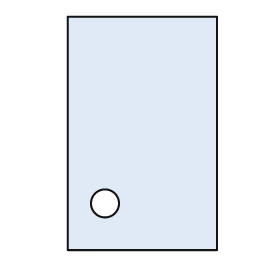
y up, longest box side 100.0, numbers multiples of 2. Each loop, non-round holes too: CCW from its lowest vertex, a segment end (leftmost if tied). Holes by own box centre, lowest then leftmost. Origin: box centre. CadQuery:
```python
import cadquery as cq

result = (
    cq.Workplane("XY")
    .moveTo(-32.0, -50.0)
    .lineTo(32.0, -50.0)
    .lineTo(32.0, 50.0)
    .lineTo(-32.0, 50.0)
    .close()
    .moveTo(-16.0, -30.0)
    .circle(6.0)
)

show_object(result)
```